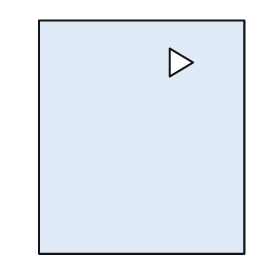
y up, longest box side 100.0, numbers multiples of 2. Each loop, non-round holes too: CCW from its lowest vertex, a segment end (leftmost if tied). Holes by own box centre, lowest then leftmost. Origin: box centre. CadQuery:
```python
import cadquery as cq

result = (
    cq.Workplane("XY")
    .moveTo(-44.0, -50.0)
    .lineTo(44.0, -50.0)
    .lineTo(44.0, 50.0)
    .lineTo(-44.0, 50.0)
    .close()
    .moveTo(12.0, 26.0)
    .lineTo(22.0, 32.0)
    .lineTo(12.0, 38.0)
    .close()
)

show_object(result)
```